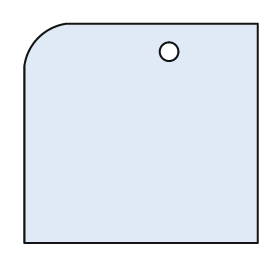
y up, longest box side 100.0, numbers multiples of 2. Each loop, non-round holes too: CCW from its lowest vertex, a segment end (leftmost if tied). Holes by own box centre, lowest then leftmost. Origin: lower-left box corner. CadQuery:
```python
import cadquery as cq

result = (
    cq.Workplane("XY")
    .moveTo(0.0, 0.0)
    .lineTo(100.0, 0.0)
    .lineTo(100.0, 94.0)
    .lineTo(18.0, 94.0)
    .threePointArc((6.0, 88.0), (0.0, 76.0))
    .close()
    .moveTo(62.0, 82.0)
    .circle(4.0)
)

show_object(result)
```